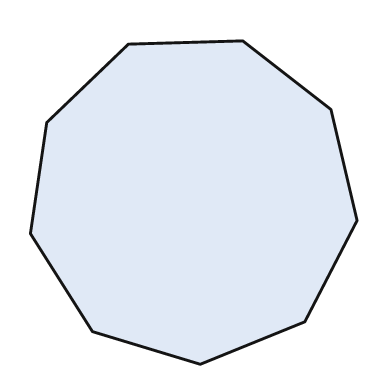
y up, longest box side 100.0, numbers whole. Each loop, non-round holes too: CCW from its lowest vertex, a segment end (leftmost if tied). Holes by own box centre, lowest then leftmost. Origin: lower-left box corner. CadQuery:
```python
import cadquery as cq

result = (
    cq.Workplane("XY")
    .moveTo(52.0, 0.0)
    .lineTo(84.0, 13.0)
    .lineTo(100.0, 44.0)
    .lineTo(92.0, 78.0)
    .lineTo(65.0, 99.0)
    .lineTo(30.0, 98.0)
    .lineTo(5.0, 74.0)
    .lineTo(0.0, 40.0)
    .lineTo(19.0, 10.0)
    .close()
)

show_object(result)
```